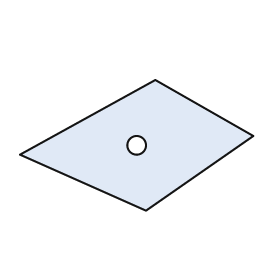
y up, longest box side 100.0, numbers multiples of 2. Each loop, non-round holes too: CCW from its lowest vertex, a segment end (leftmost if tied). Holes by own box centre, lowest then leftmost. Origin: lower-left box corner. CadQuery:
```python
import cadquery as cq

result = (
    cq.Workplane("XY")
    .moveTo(54.0, 0.0)
    .lineTo(100.0, 32.0)
    .lineTo(58.0, 56.0)
    .lineTo(0.0, 24.0)
    .close()
    .moveTo(50.0, 28.0)
    .circle(4.0)
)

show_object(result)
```